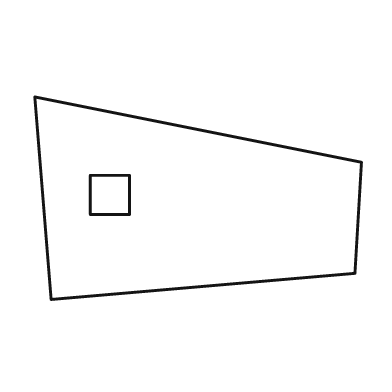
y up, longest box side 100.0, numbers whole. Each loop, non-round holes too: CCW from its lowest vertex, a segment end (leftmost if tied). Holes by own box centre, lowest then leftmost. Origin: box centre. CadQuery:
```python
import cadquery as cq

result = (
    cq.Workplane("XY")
    .moveTo(-45.0, -31.0)
    .lineTo(48.0, -23.0)
    .lineTo(50.0, 11.0)
    .lineTo(-50.0, 31.0)
    .close()
    .moveTo(-33.0, -5.0)
    .lineTo(-21.0, -5.0)
    .lineTo(-21.0, 7.0)
    .lineTo(-33.0, 7.0)
    .close()
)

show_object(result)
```